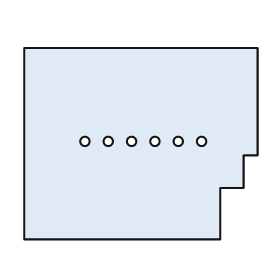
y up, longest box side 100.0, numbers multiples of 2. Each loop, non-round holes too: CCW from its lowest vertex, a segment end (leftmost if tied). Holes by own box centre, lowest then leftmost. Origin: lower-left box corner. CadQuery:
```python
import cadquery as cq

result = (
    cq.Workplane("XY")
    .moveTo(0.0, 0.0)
    .lineTo(84.0, 0.0)
    .lineTo(84.0, 22.0)
    .lineTo(94.0, 22.0)
    .lineTo(94.0, 36.0)
    .lineTo(100.0, 36.0)
    .lineTo(100.0, 82.0)
    .lineTo(0.0, 82.0)
    .close()
    .moveTo(26.0, 42.0)
    .circle(2.0)
    .moveTo(36.0, 42.0)
    .circle(2.0)
    .moveTo(46.0, 42.0)
    .circle(2.0)
    .moveTo(56.0, 42.0)
    .circle(2.0)
    .moveTo(66.0, 42.0)
    .circle(2.0)
    .moveTo(76.0, 42.0)
    .circle(2.0)
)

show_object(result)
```